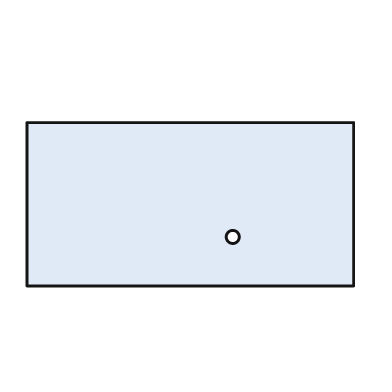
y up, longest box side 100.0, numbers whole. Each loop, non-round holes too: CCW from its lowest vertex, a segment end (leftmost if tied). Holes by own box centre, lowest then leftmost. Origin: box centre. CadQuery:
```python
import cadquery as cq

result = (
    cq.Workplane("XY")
    .moveTo(-50.0, -25.0)
    .lineTo(50.0, -25.0)
    .lineTo(50.0, 25.0)
    .lineTo(-50.0, 25.0)
    .close()
    .moveTo(13.0, -10.0)
    .circle(2.0)
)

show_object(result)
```